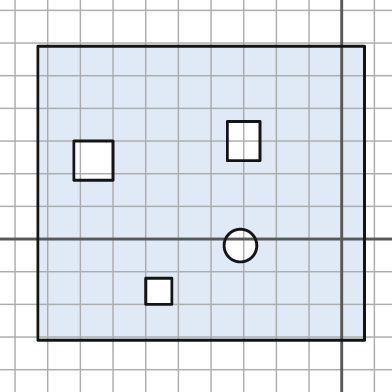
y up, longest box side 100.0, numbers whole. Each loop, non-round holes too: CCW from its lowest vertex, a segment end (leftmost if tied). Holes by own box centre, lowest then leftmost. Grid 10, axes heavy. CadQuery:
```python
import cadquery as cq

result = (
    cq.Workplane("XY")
    .moveTo(-93.0, -31.0)
    .lineTo(7.0, -31.0)
    .lineTo(7.0, 59.0)
    .lineTo(-93.0, 59.0)
    .close()
    .moveTo(-60.0, -20.0)
    .lineTo(-52.0, -20.0)
    .lineTo(-52.0, -12.0)
    .lineTo(-60.0, -12.0)
    .close()
    .moveTo(-31.0, -2.0)
    .circle(5.0)
    .moveTo(-82.0, 18.0)
    .lineTo(-70.0, 18.0)
    .lineTo(-70.0, 30.0)
    .lineTo(-82.0, 30.0)
    .close()
    .moveTo(-35.0, 24.0)
    .lineTo(-25.0, 24.0)
    .lineTo(-25.0, 36.0)
    .lineTo(-35.0, 36.0)
    .close()
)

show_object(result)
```